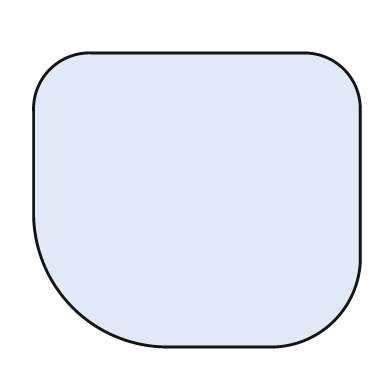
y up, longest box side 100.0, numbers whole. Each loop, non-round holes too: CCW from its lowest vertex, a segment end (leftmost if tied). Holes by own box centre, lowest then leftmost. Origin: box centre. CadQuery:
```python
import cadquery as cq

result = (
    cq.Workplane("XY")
    .moveTo(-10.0, -45.0)
    .lineTo(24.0, -45.0)
    .threePointArc((42.0, -37.0), (50.0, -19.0))
    .lineTo(50.0, 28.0)
    .threePointArc((45.0, 40.0), (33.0, 45.0))
    .lineTo(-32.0, 45.0)
    .threePointArc((-45.0, 40.0), (-50.0, 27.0))
    .lineTo(-50.0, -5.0)
    .threePointArc((-38.0, -33.0), (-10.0, -45.0))
    .close()
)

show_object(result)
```